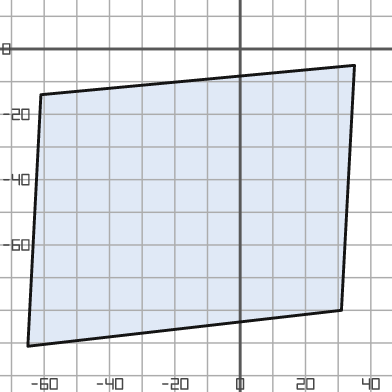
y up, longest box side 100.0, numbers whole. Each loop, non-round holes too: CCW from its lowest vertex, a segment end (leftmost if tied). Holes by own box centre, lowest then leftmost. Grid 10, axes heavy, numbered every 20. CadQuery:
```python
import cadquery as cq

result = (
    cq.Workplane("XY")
    .moveTo(-65.0, -91.0)
    .lineTo(31.0, -80.0)
    .lineTo(35.0, -5.0)
    .lineTo(-61.0, -14.0)
    .close()
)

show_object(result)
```